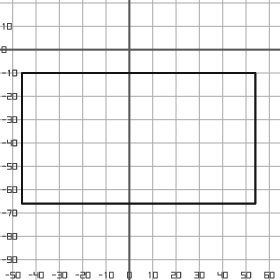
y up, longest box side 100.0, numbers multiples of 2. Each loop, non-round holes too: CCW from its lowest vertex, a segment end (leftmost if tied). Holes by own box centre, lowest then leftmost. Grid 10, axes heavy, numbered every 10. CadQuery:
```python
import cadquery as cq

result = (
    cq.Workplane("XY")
    .moveTo(-46.0, -66.0)
    .lineTo(54.0, -66.0)
    .lineTo(54.0, -10.0)
    .lineTo(-46.0, -10.0)
    .close()
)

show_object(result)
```